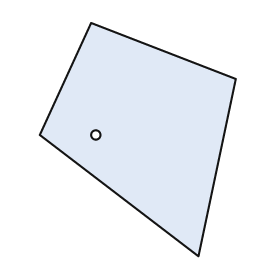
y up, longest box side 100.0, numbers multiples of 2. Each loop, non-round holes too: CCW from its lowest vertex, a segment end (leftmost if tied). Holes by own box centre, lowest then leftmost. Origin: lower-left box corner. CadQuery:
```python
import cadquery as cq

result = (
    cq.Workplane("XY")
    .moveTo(68.0, 0.0)
    .lineTo(84.0, 76.0)
    .lineTo(22.0, 100.0)
    .lineTo(0.0, 52.0)
    .close()
    .moveTo(24.0, 52.0)
    .circle(2.0)
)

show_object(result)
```